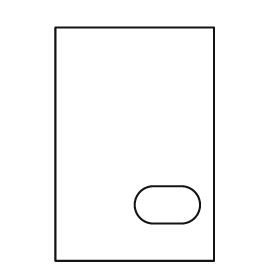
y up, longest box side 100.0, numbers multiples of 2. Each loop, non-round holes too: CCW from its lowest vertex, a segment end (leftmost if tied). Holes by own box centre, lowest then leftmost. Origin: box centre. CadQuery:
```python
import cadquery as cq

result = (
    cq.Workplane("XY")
    .moveTo(-34.0, -50.0)
    .lineTo(34.0, -50.0)
    .lineTo(34.0, 50.0)
    .lineTo(-34.0, 50.0)
    .close()
    .moveTo(8.0, -34.0)
    .lineTo(20.0, -34.0)
    .threePointArc((28.0, -26.0), (20.0, -18.0))
    .lineTo(8.0, -18.0)
    .threePointArc((0.0, -26.0), (8.0, -34.0))
    .close()
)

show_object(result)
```